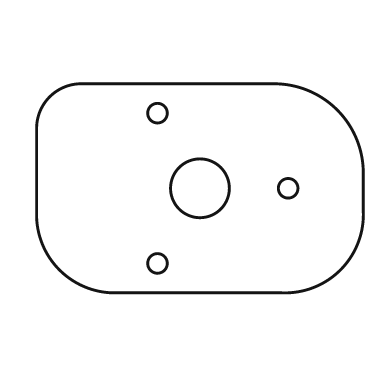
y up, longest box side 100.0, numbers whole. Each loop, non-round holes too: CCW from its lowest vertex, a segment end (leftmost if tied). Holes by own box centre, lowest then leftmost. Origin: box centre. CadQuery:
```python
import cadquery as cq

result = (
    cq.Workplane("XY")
    .moveTo(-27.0, -32.0)
    .lineTo(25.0, -32.0)
    .threePointArc((43.0, -25.0), (50.0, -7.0))
    .lineTo(50.0, 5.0)
    .threePointArc((42.0, 24.0), (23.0, 32.0))
    .lineTo(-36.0, 32.0)
    .threePointArc((-46.0, 28.0), (-50.0, 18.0))
    .lineTo(-50.0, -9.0)
    .threePointArc((-43.0, -25.0), (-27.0, -32.0))
    .close()
    .moveTo(-13.0, -23.0)
    .circle(3.0)
    .moveTo(0.0, 0.0)
    .circle(9.0)
    .moveTo(27.0, 0.0)
    .circle(3.0)
    .moveTo(-13.0, 23.0)
    .circle(3.0)
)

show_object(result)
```